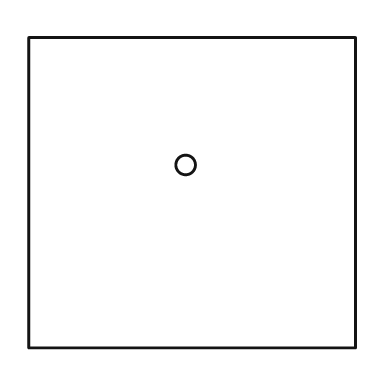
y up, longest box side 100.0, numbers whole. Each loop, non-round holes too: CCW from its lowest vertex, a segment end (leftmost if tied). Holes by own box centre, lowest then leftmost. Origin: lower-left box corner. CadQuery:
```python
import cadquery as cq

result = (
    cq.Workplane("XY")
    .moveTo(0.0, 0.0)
    .lineTo(100.0, 0.0)
    .lineTo(100.0, 95.0)
    .lineTo(0.0, 95.0)
    .close()
    .moveTo(48.0, 56.0)
    .circle(3.0)
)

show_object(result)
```